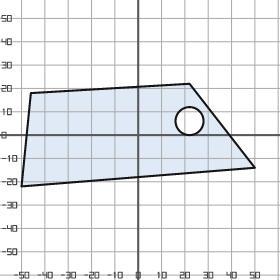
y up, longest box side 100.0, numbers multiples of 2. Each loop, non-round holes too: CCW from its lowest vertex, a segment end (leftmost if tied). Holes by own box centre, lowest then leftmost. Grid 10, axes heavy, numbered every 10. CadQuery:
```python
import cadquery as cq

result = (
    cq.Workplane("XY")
    .moveTo(-50.0, -22.0)
    .lineTo(50.0, -14.0)
    .lineTo(22.0, 22.0)
    .lineTo(-46.0, 18.0)
    .close()
    .moveTo(22.0, 6.0)
    .circle(6.0)
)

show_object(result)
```